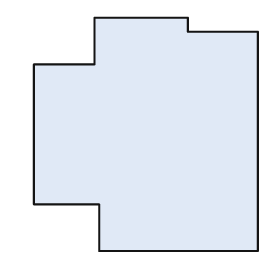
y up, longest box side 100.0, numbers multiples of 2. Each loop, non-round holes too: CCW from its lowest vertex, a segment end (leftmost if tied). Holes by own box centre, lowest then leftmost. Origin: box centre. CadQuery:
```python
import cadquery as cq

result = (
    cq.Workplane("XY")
    .moveTo(-20.0, -50.0)
    .lineTo(48.0, -50.0)
    .lineTo(48.0, 44.0)
    .lineTo(18.0, 44.0)
    .lineTo(18.0, 50.0)
    .lineTo(-22.0, 50.0)
    .lineTo(-22.0, 30.0)
    .lineTo(-48.0, 30.0)
    .lineTo(-48.0, -30.0)
    .lineTo(-20.0, -30.0)
    .close()
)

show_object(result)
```